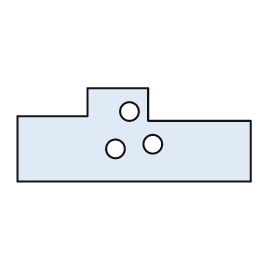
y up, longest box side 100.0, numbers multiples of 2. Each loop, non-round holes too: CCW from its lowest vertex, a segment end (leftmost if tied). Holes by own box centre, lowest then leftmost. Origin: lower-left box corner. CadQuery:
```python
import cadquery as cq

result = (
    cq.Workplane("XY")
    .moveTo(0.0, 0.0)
    .lineTo(100.0, 0.0)
    .lineTo(100.0, 26.0)
    .lineTo(56.0, 26.0)
    .lineTo(56.0, 40.0)
    .lineTo(30.0, 40.0)
    .lineTo(30.0, 28.0)
    .lineTo(0.0, 28.0)
    .close()
    .moveTo(42.0, 14.0)
    .circle(4.0)
    .moveTo(58.0, 16.0)
    .circle(4.0)
    .moveTo(48.0, 30.0)
    .circle(4.0)
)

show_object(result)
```